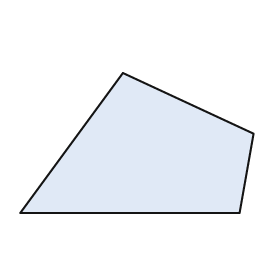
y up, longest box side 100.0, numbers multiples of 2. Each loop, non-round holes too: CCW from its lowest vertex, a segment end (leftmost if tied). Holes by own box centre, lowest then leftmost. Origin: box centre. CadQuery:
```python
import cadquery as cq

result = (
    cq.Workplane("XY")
    .moveTo(-50.0, -30.0)
    .lineTo(44.0, -30.0)
    .lineTo(50.0, 4.0)
    .lineTo(-6.0, 30.0)
    .close()
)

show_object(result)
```